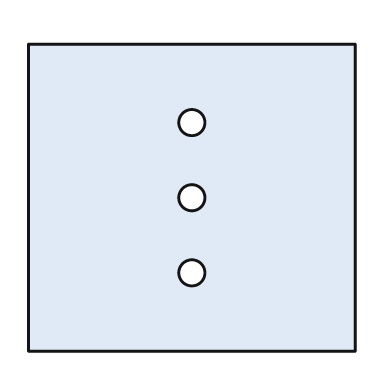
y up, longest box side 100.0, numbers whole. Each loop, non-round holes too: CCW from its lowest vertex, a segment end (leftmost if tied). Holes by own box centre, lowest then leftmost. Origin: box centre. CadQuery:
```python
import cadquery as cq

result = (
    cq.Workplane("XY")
    .moveTo(-50.0, -47.0)
    .lineTo(50.0, -47.0)
    .lineTo(50.0, 47.0)
    .lineTo(-50.0, 47.0)
    .close()
    .moveTo(0.0, -23.0)
    .circle(4.0)
    .moveTo(0.0, 0.0)
    .circle(4.0)
    .moveTo(0.0, 23.0)
    .circle(4.0)
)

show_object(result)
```